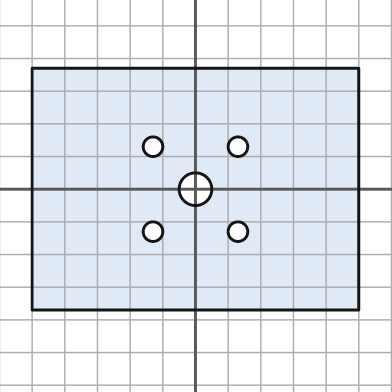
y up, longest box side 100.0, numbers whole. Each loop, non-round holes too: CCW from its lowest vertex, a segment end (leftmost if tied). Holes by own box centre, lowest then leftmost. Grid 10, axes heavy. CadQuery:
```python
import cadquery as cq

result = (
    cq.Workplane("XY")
    .moveTo(-50.0, -37.0)
    .lineTo(50.0, -37.0)
    .lineTo(50.0, 37.0)
    .lineTo(-50.0, 37.0)
    .close()
    .moveTo(-13.0, -13.0)
    .circle(3.0)
    .moveTo(13.0, -13.0)
    .circle(3.0)
    .moveTo(0.0, 0.0)
    .circle(5.0)
    .moveTo(-13.0, 13.0)
    .circle(3.0)
    .moveTo(13.0, 13.0)
    .circle(3.0)
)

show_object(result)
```